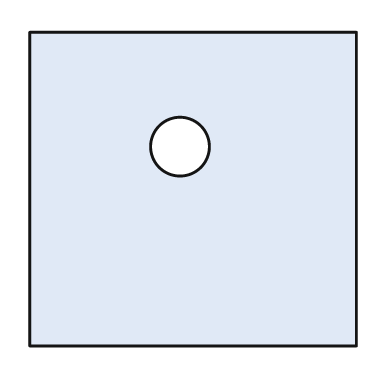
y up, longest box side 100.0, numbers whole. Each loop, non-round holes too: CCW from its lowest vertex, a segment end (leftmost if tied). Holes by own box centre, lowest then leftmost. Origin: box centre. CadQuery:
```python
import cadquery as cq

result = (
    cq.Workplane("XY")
    .moveTo(-50.0, -48.0)
    .lineTo(50.0, -48.0)
    .lineTo(50.0, 48.0)
    .lineTo(-50.0, 48.0)
    .close()
    .moveTo(-4.0, 13.0)
    .circle(9.0)
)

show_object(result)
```